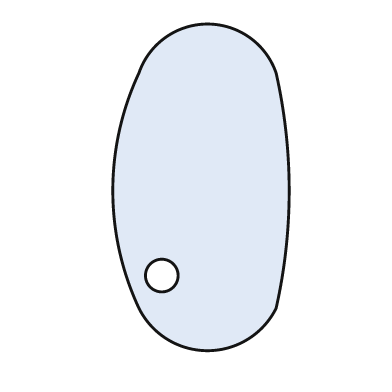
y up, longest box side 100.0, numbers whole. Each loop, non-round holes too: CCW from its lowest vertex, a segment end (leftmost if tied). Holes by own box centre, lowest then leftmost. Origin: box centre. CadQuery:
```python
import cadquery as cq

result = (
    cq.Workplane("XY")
    .moveTo(-19.0, -37.0)
    .threePointArc((2.0, -50.0), (23.0, -37.0))
    .threePointArc((27.0, -1.0), (23.0, 35.0))
    .threePointArc((2.0, 50.0), (-19.0, 35.0))
    .threePointArc((-27.0, -1.0), (-19.0, -37.0))
    .close()
    .moveTo(-12.0, -27.0)
    .circle(5.0)
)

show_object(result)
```